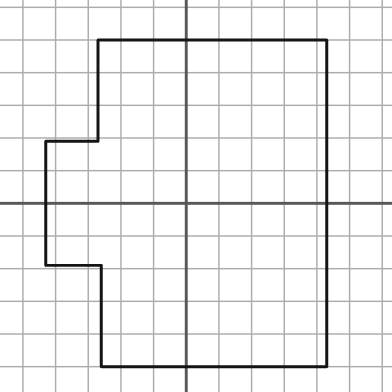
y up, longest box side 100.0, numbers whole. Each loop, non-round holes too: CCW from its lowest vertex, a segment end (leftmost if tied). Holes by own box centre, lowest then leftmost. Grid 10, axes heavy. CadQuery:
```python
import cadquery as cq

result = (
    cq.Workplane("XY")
    .moveTo(-26.0, -50.0)
    .lineTo(43.0, -50.0)
    .lineTo(43.0, 50.0)
    .lineTo(-27.0, 50.0)
    .lineTo(-27.0, 19.0)
    .lineTo(-43.0, 19.0)
    .lineTo(-43.0, -19.0)
    .lineTo(-26.0, -19.0)
    .close()
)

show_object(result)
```